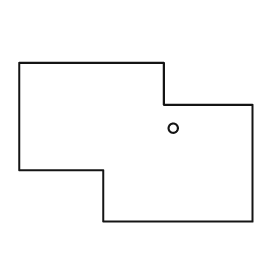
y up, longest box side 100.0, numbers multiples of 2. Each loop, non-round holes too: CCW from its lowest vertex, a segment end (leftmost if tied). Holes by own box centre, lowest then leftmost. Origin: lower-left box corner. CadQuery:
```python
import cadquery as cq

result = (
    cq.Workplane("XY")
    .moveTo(36.0, 0.0)
    .lineTo(100.0, 0.0)
    .lineTo(100.0, 50.0)
    .lineTo(62.0, 50.0)
    .lineTo(62.0, 68.0)
    .lineTo(0.0, 68.0)
    .lineTo(0.0, 22.0)
    .lineTo(36.0, 22.0)
    .close()
    .moveTo(66.0, 40.0)
    .circle(2.0)
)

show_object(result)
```